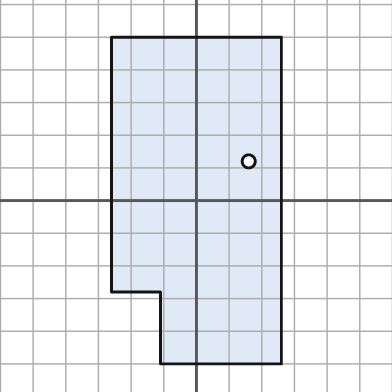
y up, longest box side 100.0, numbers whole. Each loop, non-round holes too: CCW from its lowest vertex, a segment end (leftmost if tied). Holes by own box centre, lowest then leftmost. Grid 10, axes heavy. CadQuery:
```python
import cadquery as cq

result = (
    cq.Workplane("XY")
    .moveTo(-11.0, -50.0)
    .lineTo(26.0, -50.0)
    .lineTo(26.0, 50.0)
    .lineTo(-26.0, 50.0)
    .lineTo(-26.0, -28.0)
    .lineTo(-11.0, -28.0)
    .close()
    .moveTo(16.0, 12.0)
    .circle(2.0)
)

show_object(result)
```